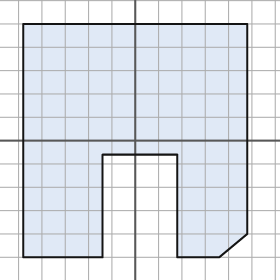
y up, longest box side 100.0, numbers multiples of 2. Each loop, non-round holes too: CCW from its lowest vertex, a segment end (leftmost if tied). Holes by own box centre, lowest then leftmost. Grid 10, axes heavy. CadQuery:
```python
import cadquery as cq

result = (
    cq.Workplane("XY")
    .moveTo(-48.0, -50.0)
    .lineTo(-14.0, -50.0)
    .lineTo(-14.0, -6.0)
    .lineTo(18.0, -6.0)
    .lineTo(18.0, -50.0)
    .lineTo(36.0, -50.0)
    .lineTo(48.0, -40.0)
    .lineTo(48.0, 50.0)
    .lineTo(-48.0, 50.0)
    .close()
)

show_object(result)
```